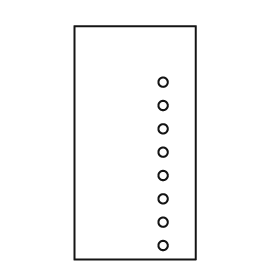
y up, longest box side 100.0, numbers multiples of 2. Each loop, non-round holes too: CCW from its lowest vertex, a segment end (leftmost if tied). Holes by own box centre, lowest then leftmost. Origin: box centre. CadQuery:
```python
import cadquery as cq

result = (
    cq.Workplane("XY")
    .moveTo(-26.0, -50.0)
    .lineTo(26.0, -50.0)
    .lineTo(26.0, 50.0)
    .lineTo(-26.0, 50.0)
    .close()
    .moveTo(12.0, -44.0)
    .circle(2.0)
    .moveTo(12.0, -34.0)
    .circle(2.0)
    .moveTo(12.0, -24.0)
    .circle(2.0)
    .moveTo(12.0, -14.0)
    .circle(2.0)
    .moveTo(12.0, -4.0)
    .circle(2.0)
    .moveTo(12.0, 6.0)
    .circle(2.0)
    .moveTo(12.0, 16.0)
    .circle(2.0)
    .moveTo(12.0, 26.0)
    .circle(2.0)
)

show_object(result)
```